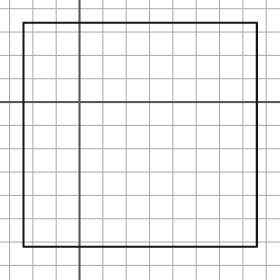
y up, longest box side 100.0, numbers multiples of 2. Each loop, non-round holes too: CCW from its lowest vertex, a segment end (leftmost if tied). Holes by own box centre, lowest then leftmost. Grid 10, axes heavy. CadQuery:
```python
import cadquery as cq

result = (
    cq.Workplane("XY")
    .moveTo(-24.0, -62.0)
    .lineTo(76.0, -62.0)
    .lineTo(76.0, 34.0)
    .lineTo(-24.0, 34.0)
    .close()
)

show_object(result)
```